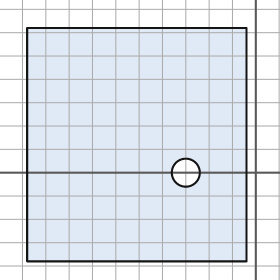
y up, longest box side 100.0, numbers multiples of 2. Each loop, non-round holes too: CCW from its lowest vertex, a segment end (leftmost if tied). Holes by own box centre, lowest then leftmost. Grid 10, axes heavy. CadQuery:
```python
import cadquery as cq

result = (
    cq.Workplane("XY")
    .moveTo(-98.0, -38.0)
    .lineTo(-4.0, -38.0)
    .lineTo(-4.0, 62.0)
    .lineTo(-98.0, 62.0)
    .close()
    .moveTo(-30.0, 0.0)
    .circle(6.0)
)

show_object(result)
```